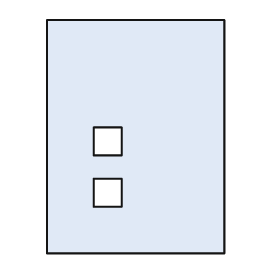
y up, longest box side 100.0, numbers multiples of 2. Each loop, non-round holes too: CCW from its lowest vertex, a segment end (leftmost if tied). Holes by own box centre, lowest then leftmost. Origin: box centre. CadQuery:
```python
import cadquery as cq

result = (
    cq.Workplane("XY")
    .moveTo(-38.0, -50.0)
    .lineTo(38.0, -50.0)
    .lineTo(38.0, 50.0)
    .lineTo(-38.0, 50.0)
    .close()
    .moveTo(-18.0, -30.0)
    .lineTo(-6.0, -30.0)
    .lineTo(-6.0, -18.0)
    .lineTo(-18.0, -18.0)
    .close()
    .moveTo(-18.0, -8.0)
    .lineTo(-6.0, -8.0)
    .lineTo(-6.0, 4.0)
    .lineTo(-18.0, 4.0)
    .close()
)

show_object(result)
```